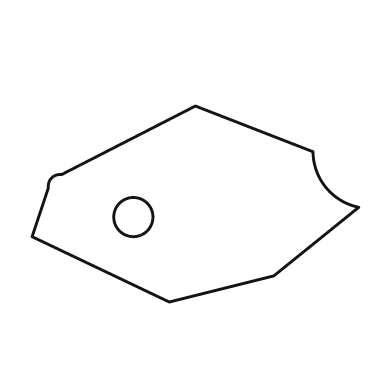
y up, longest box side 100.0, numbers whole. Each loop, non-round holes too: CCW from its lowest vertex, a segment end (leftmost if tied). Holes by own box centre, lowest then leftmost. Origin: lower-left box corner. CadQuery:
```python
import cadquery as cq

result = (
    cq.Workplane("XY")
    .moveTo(42.0, 0.0)
    .lineTo(74.0, 8.0)
    .lineTo(100.0, 29.0)
    .threePointArc((90.0, 35.0), (86.0, 46.0))
    .lineTo(50.0, 60.0)
    .lineTo(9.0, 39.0)
    .threePointArc((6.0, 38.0), (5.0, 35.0))
    .lineTo(0.0, 20.0)
    .close()
    .moveTo(31.0, 26.0)
    .circle(6.0)
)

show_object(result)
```